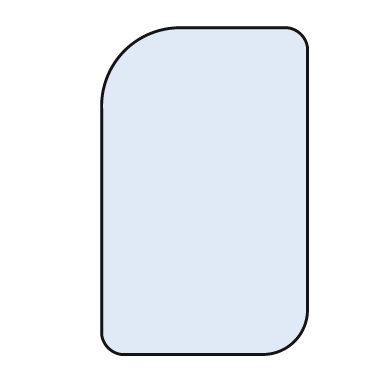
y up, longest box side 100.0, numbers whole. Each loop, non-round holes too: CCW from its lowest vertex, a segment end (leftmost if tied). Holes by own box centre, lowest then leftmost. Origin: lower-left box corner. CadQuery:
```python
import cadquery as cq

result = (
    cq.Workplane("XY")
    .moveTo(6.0, 0.0)
    .lineTo(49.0, 0.0)
    .threePointArc((59.0, 4.0), (63.0, 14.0))
    .lineTo(63.0, 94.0)
    .threePointArc((61.0, 98.0), (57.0, 100.0))
    .lineTo(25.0, 100.0)
    .threePointArc((7.0, 93.0), (0.0, 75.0))
    .lineTo(0.0, 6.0)
    .threePointArc((2.0, 2.0), (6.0, 0.0))
    .close()
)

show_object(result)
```